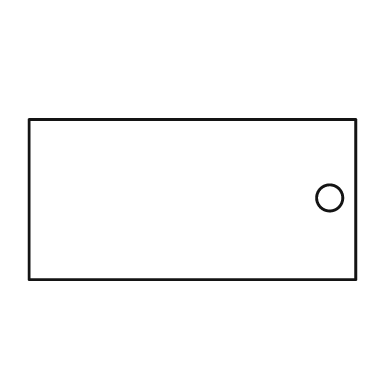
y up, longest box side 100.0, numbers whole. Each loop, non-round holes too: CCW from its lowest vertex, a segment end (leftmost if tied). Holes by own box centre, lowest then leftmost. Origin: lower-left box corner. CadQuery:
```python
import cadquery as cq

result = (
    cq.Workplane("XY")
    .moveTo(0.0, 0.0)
    .lineTo(100.0, 0.0)
    .lineTo(100.0, 49.0)
    .lineTo(0.0, 49.0)
    .close()
    .moveTo(92.0, 25.0)
    .circle(4.0)
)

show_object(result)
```